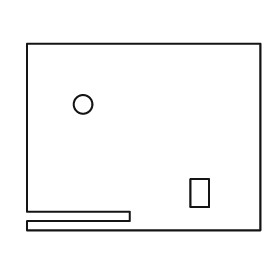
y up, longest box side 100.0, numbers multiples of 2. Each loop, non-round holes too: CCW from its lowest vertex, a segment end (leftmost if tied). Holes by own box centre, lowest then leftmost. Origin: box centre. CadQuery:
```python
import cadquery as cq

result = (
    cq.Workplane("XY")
    .moveTo(-50.0, -40.0)
    .lineTo(50.0, -40.0)
    .lineTo(50.0, 40.0)
    .lineTo(-50.0, 40.0)
    .lineTo(-50.0, -32.0)
    .lineTo(-6.0, -32.0)
    .lineTo(-6.0, -36.0)
    .lineTo(-50.0, -36.0)
    .close()
    .moveTo(20.0, -30.0)
    .lineTo(28.0, -30.0)
    .lineTo(28.0, -18.0)
    .lineTo(20.0, -18.0)
    .close()
    .moveTo(-26.0, 14.0)
    .circle(4.0)
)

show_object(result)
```